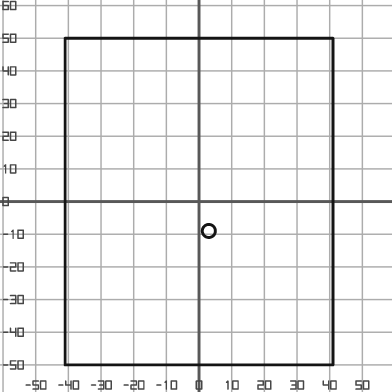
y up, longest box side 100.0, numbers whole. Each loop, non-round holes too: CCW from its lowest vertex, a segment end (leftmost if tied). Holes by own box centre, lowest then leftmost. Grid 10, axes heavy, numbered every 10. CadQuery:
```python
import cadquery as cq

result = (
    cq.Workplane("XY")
    .moveTo(-41.0, -50.0)
    .lineTo(41.0, -50.0)
    .lineTo(41.0, 50.0)
    .lineTo(-41.0, 50.0)
    .close()
    .moveTo(3.0, -9.0)
    .circle(2.0)
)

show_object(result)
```